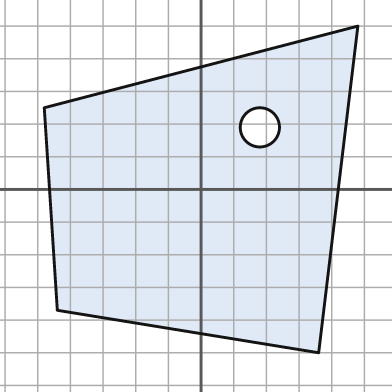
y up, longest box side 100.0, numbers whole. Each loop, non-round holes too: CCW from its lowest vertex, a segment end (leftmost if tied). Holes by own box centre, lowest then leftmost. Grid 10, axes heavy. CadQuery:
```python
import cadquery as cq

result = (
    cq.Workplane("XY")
    .moveTo(36.0, -50.0)
    .lineTo(48.0, 50.0)
    .lineTo(-48.0, 25.0)
    .lineTo(-44.0, -37.0)
    .close()
    .moveTo(18.0, 19.0)
    .circle(6.0)
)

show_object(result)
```